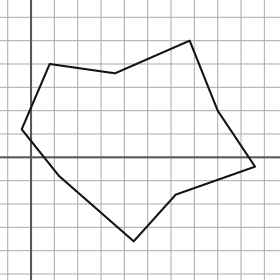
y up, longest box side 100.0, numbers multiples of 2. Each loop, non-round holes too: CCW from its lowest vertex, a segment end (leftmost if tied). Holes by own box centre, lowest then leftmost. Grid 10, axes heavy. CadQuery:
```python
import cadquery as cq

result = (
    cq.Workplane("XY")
    .moveTo(44.0, -36.0)
    .lineTo(62.0, -16.0)
    .lineTo(96.0, -4.0)
    .lineTo(80.0, 20.0)
    .lineTo(68.0, 50.0)
    .lineTo(36.0, 36.0)
    .lineTo(8.0, 40.0)
    .lineTo(-4.0, 12.0)
    .lineTo(12.0, -8.0)
    .close()
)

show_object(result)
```